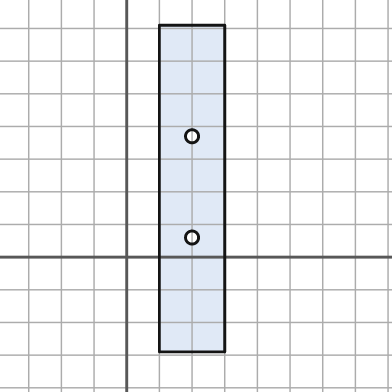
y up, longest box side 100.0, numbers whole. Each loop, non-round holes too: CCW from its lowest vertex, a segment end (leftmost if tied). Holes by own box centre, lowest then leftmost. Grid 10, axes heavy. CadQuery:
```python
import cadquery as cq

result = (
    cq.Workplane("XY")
    .moveTo(10.0, -29.0)
    .lineTo(30.0, -29.0)
    .lineTo(30.0, 71.0)
    .lineTo(10.0, 71.0)
    .close()
    .moveTo(20.0, 6.0)
    .circle(2.0)
    .moveTo(20.0, 37.0)
    .circle(2.0)
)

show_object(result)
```